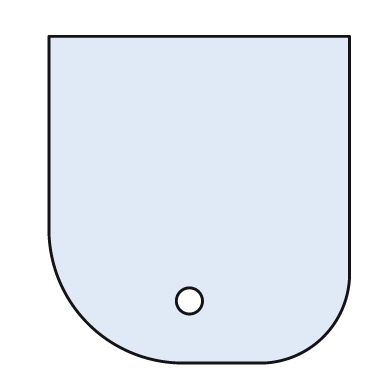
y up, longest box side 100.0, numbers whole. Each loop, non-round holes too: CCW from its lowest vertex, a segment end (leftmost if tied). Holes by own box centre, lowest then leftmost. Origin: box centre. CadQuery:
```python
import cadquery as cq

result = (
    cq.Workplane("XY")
    .moveTo(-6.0, -50.0)
    .lineTo(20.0, -50.0)
    .threePointArc((38.0, -42.0), (46.0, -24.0))
    .lineTo(46.0, 50.0)
    .lineTo(-46.0, 50.0)
    .lineTo(-46.0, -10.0)
    .threePointArc((-34.0, -38.0), (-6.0, -50.0))
    .close()
    .moveTo(-3.0, -31.0)
    .circle(4.0)
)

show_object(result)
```